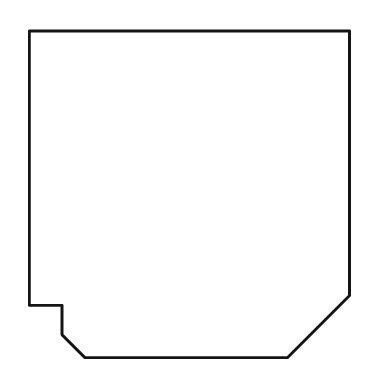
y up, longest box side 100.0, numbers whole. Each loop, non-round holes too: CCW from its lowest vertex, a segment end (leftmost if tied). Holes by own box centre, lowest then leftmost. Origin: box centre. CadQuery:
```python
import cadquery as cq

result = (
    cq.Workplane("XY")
    .moveTo(-32.0, -50.0)
    .lineTo(30.0, -50.0)
    .lineTo(49.0, -31.0)
    .lineTo(49.0, 50.0)
    .lineTo(-49.0, 50.0)
    .lineTo(-49.0, -34.0)
    .lineTo(-39.0, -34.0)
    .lineTo(-39.0, -43.0)
    .close()
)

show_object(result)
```